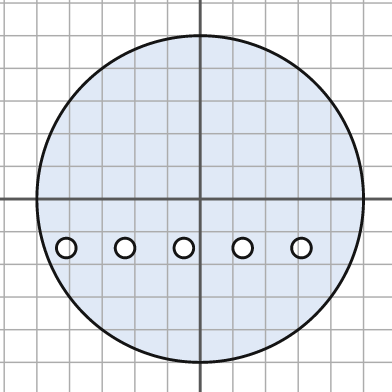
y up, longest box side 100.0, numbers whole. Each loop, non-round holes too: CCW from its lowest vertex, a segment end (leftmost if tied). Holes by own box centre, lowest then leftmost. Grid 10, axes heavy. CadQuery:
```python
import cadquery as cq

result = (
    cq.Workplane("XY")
    .moveTo(0.0, 0.0)
    .circle(50.0)
    .moveTo(-41.0, -15.0)
    .circle(3.0)
    .moveTo(-23.0, -15.0)
    .circle(3.0)
    .moveTo(-5.0, -15.0)
    .circle(3.0)
    .moveTo(13.0, -15.0)
    .circle(3.0)
    .moveTo(31.0, -15.0)
    .circle(3.0)
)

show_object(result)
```